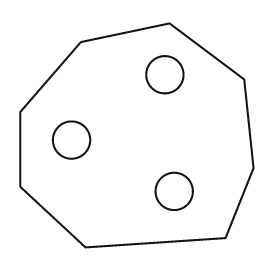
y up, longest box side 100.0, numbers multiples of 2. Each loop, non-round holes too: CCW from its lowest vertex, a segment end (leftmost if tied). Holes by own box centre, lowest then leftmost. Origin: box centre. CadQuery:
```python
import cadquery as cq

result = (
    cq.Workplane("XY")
    .moveTo(-22.0, -48.0)
    .lineTo(38.0, -44.0)
    .lineTo(50.0, -14.0)
    .lineTo(46.0, 24.0)
    .lineTo(14.0, 48.0)
    .lineTo(-24.0, 40.0)
    .lineTo(-50.0, 10.0)
    .lineTo(-50.0, -22.0)
    .close()
    .moveTo(16.0, -24.0)
    .circle(8.0)
    .moveTo(-28.0, -2.0)
    .circle(8.0)
    .moveTo(12.0, 26.0)
    .circle(8.0)
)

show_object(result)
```